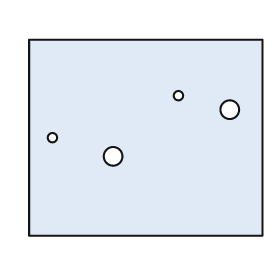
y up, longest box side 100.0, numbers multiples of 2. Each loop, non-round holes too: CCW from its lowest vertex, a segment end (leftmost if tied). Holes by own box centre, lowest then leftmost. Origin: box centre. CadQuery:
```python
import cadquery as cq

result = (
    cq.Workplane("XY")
    .moveTo(-50.0, -42.0)
    .lineTo(50.0, -42.0)
    .lineTo(50.0, 42.0)
    .lineTo(-50.0, 42.0)
    .close()
    .moveTo(-14.0, -8.0)
    .circle(4.0)
    .moveTo(-40.0, 0.0)
    .circle(2.0)
    .moveTo(36.0, 12.0)
    .circle(4.0)
    .moveTo(14.0, 18.0)
    .circle(2.0)
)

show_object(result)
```